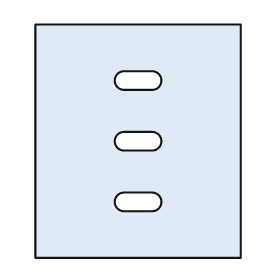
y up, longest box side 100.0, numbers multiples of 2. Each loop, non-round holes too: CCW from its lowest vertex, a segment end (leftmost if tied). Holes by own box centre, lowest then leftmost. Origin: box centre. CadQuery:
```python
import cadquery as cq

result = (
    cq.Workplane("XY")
    .moveTo(-44.0, -50.0)
    .lineTo(44.0, -50.0)
    .lineTo(44.0, 50.0)
    .lineTo(-44.0, 50.0)
    .close()
    .moveTo(-6.0, -30.0)
    .lineTo(6.0, -30.0)
    .threePointArc((10.0, -26.0), (6.0, -22.0))
    .lineTo(-6.0, -22.0)
    .threePointArc((-10.0, -26.0), (-6.0, -30.0))
    .close()
    .moveTo(-6.0, -4.0)
    .lineTo(6.0, -4.0)
    .threePointArc((10.0, 0.0), (6.0, 4.0))
    .lineTo(-6.0, 4.0)
    .threePointArc((-10.0, 0.0), (-6.0, -4.0))
    .close()
    .moveTo(-6.0, 22.0)
    .lineTo(6.0, 22.0)
    .threePointArc((10.0, 26.0), (6.0, 30.0))
    .lineTo(-6.0, 30.0)
    .threePointArc((-10.0, 26.0), (-6.0, 22.0))
    .close()
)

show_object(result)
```